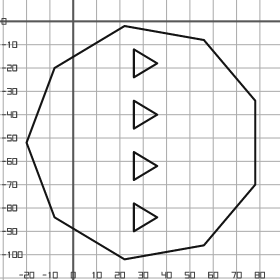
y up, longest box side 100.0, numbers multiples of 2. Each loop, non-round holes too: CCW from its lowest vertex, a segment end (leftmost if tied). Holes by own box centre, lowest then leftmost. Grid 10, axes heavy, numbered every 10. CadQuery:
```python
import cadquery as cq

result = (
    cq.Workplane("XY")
    .moveTo(22.0, -102.0)
    .lineTo(56.0, -96.0)
    .lineTo(78.0, -70.0)
    .lineTo(78.0, -34.0)
    .lineTo(56.0, -8.0)
    .lineTo(22.0, -2.0)
    .lineTo(-8.0, -20.0)
    .lineTo(-20.0, -52.0)
    .lineTo(-8.0, -84.0)
    .close()
    .moveTo(26.0, -90.0)
    .lineTo(36.0, -84.0)
    .lineTo(26.0, -78.0)
    .close()
    .moveTo(26.0, -68.0)
    .lineTo(36.0, -62.0)
    .lineTo(26.0, -56.0)
    .close()
    .moveTo(26.0, -46.0)
    .lineTo(36.0, -40.0)
    .lineTo(26.0, -34.0)
    .close()
    .moveTo(26.0, -24.0)
    .lineTo(36.0, -18.0)
    .lineTo(26.0, -12.0)
    .close()
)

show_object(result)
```